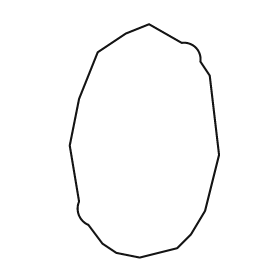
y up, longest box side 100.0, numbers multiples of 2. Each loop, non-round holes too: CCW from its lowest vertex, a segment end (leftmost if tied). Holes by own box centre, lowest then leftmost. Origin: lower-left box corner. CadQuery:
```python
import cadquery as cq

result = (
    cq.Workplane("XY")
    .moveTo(30.0, 0.0)
    .lineTo(46.0, 4.0)
    .lineTo(52.0, 10.0)
    .lineTo(58.0, 20.0)
    .lineTo(64.0, 44.0)
    .lineTo(60.0, 78.0)
    .lineTo(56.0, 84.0)
    .threePointArc((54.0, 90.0), (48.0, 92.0))
    .lineTo(34.0, 100.0)
    .lineTo(24.0, 96.0)
    .lineTo(12.0, 88.0)
    .lineTo(4.0, 68.0)
    .lineTo(0.0, 48.0)
    .lineTo(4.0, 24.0)
    .threePointArc((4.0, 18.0), (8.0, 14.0))
    .lineTo(14.0, 6.0)
    .lineTo(20.0, 2.0)
    .close()
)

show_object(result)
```